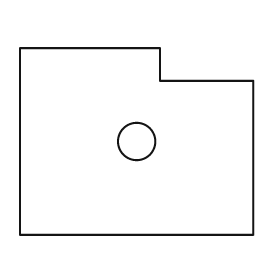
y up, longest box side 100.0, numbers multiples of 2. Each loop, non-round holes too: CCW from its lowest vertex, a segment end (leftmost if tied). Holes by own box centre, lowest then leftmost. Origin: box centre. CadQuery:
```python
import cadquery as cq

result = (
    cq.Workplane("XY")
    .moveTo(-50.0, -40.0)
    .lineTo(50.0, -40.0)
    .lineTo(50.0, 26.0)
    .lineTo(10.0, 26.0)
    .lineTo(10.0, 40.0)
    .lineTo(-50.0, 40.0)
    .close()
    .moveTo(0.0, 0.0)
    .circle(8.0)
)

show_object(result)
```